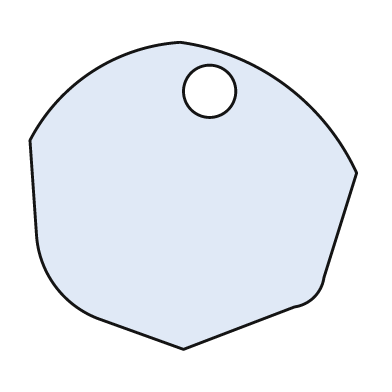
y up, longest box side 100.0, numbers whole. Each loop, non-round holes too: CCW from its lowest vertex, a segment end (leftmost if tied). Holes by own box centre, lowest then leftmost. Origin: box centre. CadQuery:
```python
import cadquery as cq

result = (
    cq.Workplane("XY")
    .moveTo(-3.0, -47.0)
    .lineTo(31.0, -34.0)
    .threePointArc((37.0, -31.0), (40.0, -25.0))
    .lineTo(50.0, 7.0)
    .threePointArc((28.0, 34.0), (-4.0, 47.0))
    .threePointArc((-31.0, 38.0), (-50.0, 17.0))
    .lineTo(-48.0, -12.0)
    .threePointArc((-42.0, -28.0), (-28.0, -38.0))
    .close()
    .moveTo(5.0, 32.0)
    .circle(8.0)
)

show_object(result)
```